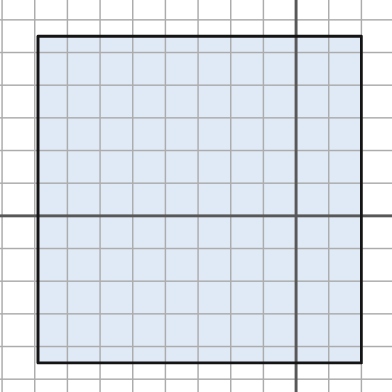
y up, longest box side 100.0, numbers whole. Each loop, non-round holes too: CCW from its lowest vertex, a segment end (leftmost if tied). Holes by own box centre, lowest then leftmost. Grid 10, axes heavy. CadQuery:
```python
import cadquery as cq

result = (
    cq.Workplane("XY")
    .moveTo(-79.0, -45.0)
    .lineTo(20.0, -45.0)
    .lineTo(20.0, 55.0)
    .lineTo(-79.0, 55.0)
    .close()
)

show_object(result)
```